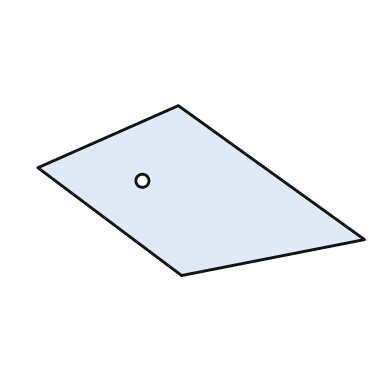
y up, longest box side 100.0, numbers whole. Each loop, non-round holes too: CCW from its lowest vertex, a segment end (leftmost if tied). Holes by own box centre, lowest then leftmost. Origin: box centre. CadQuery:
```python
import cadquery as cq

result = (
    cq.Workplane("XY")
    .moveTo(-6.0, -26.0)
    .lineTo(50.0, -15.0)
    .lineTo(-7.0, 26.0)
    .lineTo(-50.0, 7.0)
    .close()
    .moveTo(-18.0, 3.0)
    .circle(2.0)
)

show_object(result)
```